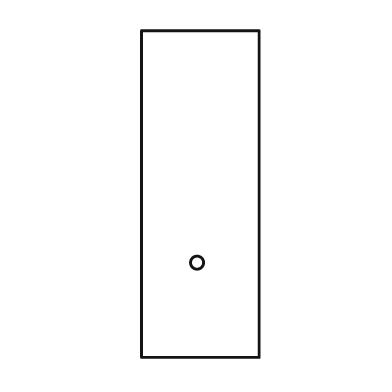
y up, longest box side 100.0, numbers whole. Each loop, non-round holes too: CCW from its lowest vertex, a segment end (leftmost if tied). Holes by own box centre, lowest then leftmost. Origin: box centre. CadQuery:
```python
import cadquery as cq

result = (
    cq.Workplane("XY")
    .moveTo(-18.0, -50.0)
    .lineTo(18.0, -50.0)
    .lineTo(18.0, 50.0)
    .lineTo(-18.0, 50.0)
    .close()
    .moveTo(-1.0, -21.0)
    .circle(2.0)
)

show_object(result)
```